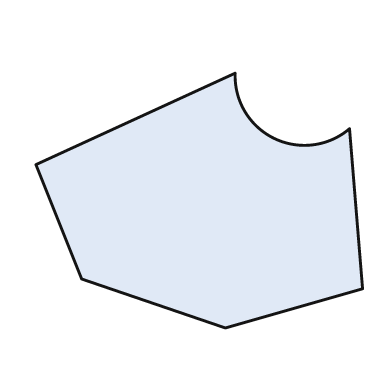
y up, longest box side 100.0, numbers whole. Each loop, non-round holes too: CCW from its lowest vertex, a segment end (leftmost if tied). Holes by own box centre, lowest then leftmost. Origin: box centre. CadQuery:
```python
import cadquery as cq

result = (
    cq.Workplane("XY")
    .moveTo(8.0, -39.0)
    .lineTo(50.0, -27.0)
    .lineTo(46.0, 22.0)
    .threePointArc((23.0, 19.0), (11.0, 39.0))
    .lineTo(-50.0, 11.0)
    .lineTo(-36.0, -24.0)
    .close()
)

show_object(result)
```